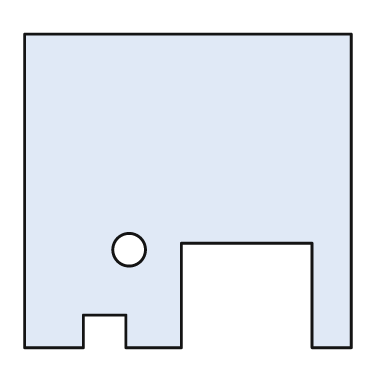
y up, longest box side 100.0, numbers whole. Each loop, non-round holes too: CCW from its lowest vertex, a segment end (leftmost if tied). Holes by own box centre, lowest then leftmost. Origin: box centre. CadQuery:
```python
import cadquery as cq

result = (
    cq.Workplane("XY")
    .moveTo(-50.0, -48.0)
    .lineTo(-32.0, -48.0)
    .lineTo(-32.0, -38.0)
    .lineTo(-19.0, -38.0)
    .lineTo(-19.0, -48.0)
    .lineTo(-2.0, -48.0)
    .lineTo(-2.0, -16.0)
    .lineTo(38.0, -16.0)
    .lineTo(38.0, -48.0)
    .lineTo(50.0, -48.0)
    .lineTo(50.0, 48.0)
    .lineTo(-50.0, 48.0)
    .close()
    .moveTo(-18.0, -18.0)
    .circle(5.0)
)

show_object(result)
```